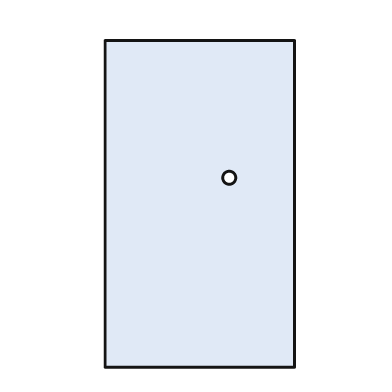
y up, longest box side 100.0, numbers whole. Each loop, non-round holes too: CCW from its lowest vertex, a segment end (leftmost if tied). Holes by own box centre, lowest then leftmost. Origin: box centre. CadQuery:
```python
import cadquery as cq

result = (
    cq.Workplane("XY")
    .moveTo(-29.0, -50.0)
    .lineTo(29.0, -50.0)
    .lineTo(29.0, 50.0)
    .lineTo(-29.0, 50.0)
    .close()
    .moveTo(9.0, 8.0)
    .circle(2.0)
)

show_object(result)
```